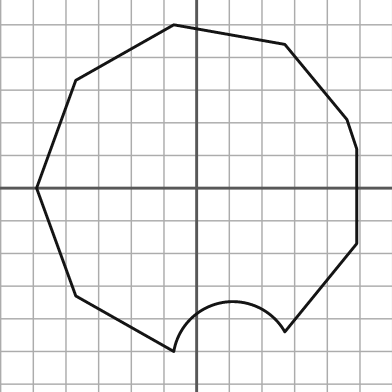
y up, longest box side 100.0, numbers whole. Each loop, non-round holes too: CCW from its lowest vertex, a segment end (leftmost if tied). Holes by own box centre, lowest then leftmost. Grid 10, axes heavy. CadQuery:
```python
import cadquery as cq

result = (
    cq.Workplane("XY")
    .moveTo(-7.0, -50.0)
    .threePointArc((8.0, -35.0), (27.0, -44.0))
    .lineTo(49.0, -17.0)
    .lineTo(49.0, 12.0)
    .lineTo(46.0, 21.0)
    .lineTo(27.0, 44.0)
    .lineTo(-7.0, 50.0)
    .lineTo(-37.0, 33.0)
    .lineTo(-49.0, 0.0)
    .lineTo(-37.0, -33.0)
    .close()
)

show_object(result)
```